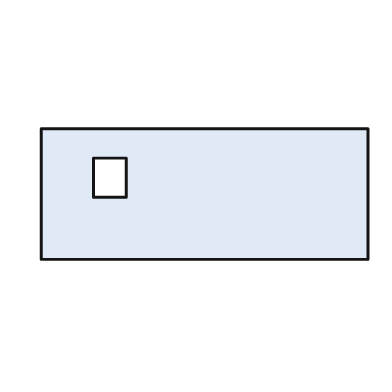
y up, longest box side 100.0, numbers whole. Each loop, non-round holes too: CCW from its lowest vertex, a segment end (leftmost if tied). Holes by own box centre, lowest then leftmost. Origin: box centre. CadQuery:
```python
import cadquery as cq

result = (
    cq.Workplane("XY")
    .moveTo(-50.0, -20.0)
    .lineTo(50.0, -20.0)
    .lineTo(50.0, 20.0)
    .lineTo(-50.0, 20.0)
    .close()
    .moveTo(-34.0, -1.0)
    .lineTo(-24.0, -1.0)
    .lineTo(-24.0, 11.0)
    .lineTo(-34.0, 11.0)
    .close()
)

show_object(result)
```